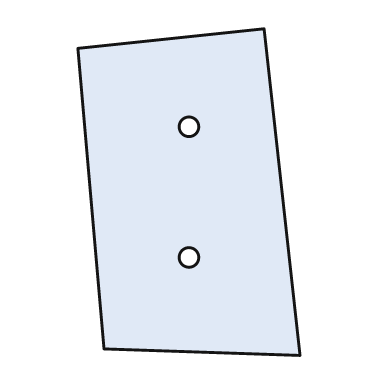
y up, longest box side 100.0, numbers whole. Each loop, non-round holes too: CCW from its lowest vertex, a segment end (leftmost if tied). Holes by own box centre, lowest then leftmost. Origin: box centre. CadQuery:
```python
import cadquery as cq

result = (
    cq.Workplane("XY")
    .moveTo(34.0, -50.0)
    .lineTo(23.0, 50.0)
    .lineTo(-34.0, 44.0)
    .lineTo(-26.0, -48.0)
    .close()
    .moveTo(0.0, -20.0)
    .circle(3.0)
    .moveTo(0.0, 20.0)
    .circle(3.0)
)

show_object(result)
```